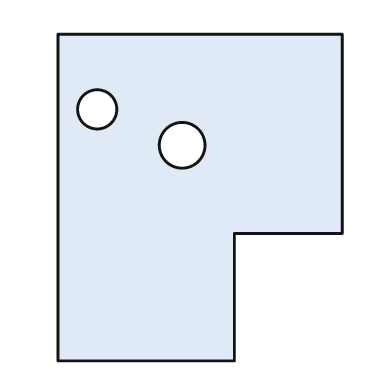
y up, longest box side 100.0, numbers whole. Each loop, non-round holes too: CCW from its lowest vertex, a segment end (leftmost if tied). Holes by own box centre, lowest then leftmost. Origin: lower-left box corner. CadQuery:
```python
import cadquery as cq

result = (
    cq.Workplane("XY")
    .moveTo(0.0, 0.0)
    .lineTo(54.0, 0.0)
    .lineTo(54.0, 39.0)
    .lineTo(87.0, 39.0)
    .lineTo(87.0, 100.0)
    .lineTo(0.0, 100.0)
    .close()
    .moveTo(38.0, 66.0)
    .circle(7.0)
    .moveTo(12.0, 77.0)
    .circle(6.0)
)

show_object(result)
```